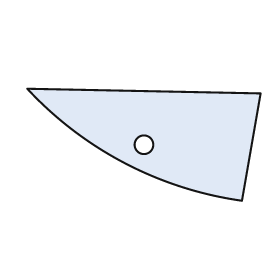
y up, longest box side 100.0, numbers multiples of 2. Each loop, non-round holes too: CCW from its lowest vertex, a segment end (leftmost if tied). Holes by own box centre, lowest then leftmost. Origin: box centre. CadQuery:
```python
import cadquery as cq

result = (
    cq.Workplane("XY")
    .moveTo(42.0, -24.0)
    .lineTo(50.0, 22.0)
    .lineTo(-50.0, 24.0)
    .threePointArc((-8.0, -8.0), (42.0, -24.0))
    .close()
    .moveTo(0.0, 0.0)
    .circle(4.0)
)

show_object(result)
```